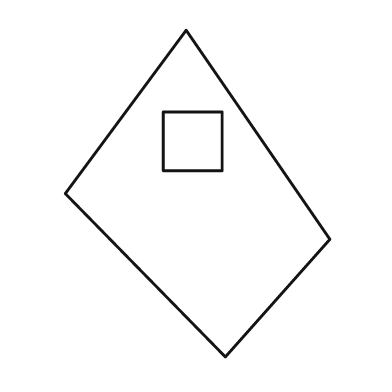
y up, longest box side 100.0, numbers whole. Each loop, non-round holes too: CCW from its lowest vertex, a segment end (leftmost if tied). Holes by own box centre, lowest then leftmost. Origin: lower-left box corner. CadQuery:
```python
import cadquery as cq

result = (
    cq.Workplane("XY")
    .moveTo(49.0, 0.0)
    .lineTo(81.0, 36.0)
    .lineTo(37.0, 100.0)
    .lineTo(0.0, 50.0)
    .close()
    .moveTo(30.0, 57.0)
    .lineTo(48.0, 57.0)
    .lineTo(48.0, 75.0)
    .lineTo(30.0, 75.0)
    .close()
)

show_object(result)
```